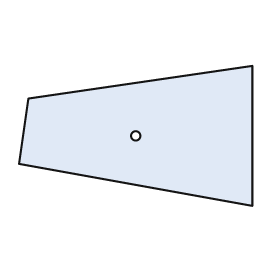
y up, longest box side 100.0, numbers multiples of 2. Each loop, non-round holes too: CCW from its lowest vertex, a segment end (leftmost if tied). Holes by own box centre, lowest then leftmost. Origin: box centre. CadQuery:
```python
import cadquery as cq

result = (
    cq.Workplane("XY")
    .moveTo(50.0, -30.0)
    .lineTo(50.0, 30.0)
    .lineTo(-46.0, 16.0)
    .lineTo(-50.0, -12.0)
    .close()
    .moveTo(0.0, 0.0)
    .circle(2.0)
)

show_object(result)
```